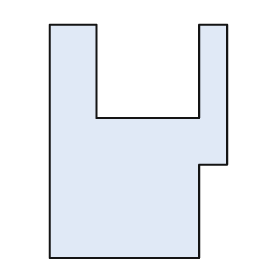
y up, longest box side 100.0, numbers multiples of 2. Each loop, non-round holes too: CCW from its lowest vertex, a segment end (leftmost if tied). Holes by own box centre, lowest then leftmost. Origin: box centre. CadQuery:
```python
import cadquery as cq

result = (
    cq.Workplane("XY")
    .moveTo(-38.0, -50.0)
    .lineTo(26.0, -50.0)
    .lineTo(26.0, -10.0)
    .lineTo(38.0, -10.0)
    .lineTo(38.0, 50.0)
    .lineTo(26.0, 50.0)
    .lineTo(26.0, 10.0)
    .lineTo(-18.0, 10.0)
    .lineTo(-18.0, 50.0)
    .lineTo(-38.0, 50.0)
    .close()
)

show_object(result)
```